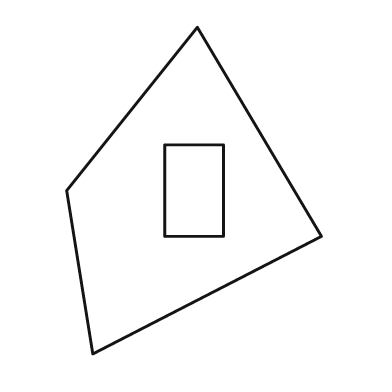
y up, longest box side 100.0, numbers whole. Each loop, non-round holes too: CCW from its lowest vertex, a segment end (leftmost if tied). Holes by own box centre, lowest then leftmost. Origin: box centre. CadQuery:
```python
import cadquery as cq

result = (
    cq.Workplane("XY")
    .moveTo(-31.0, -50.0)
    .lineTo(39.0, -14.0)
    .lineTo(1.0, 50.0)
    .lineTo(-39.0, 0.0)
    .close()
    .moveTo(-9.0, -14.0)
    .lineTo(9.0, -14.0)
    .lineTo(9.0, 14.0)
    .lineTo(-9.0, 14.0)
    .close()
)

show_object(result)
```